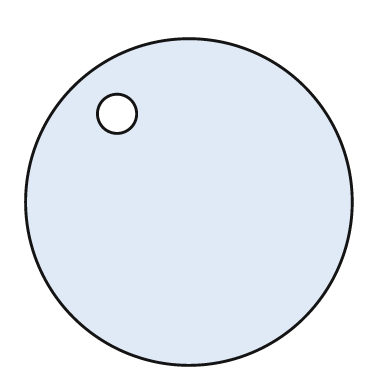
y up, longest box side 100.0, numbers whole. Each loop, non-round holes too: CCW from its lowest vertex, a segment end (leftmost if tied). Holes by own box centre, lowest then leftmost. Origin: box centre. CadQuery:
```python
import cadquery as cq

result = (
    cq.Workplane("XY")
    .moveTo(0.0, 0.0)
    .circle(50.0)
    .moveTo(-22.0, 27.0)
    .circle(6.0)
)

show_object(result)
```